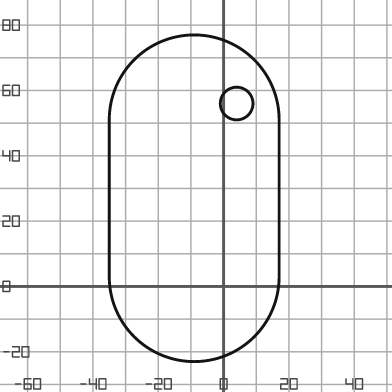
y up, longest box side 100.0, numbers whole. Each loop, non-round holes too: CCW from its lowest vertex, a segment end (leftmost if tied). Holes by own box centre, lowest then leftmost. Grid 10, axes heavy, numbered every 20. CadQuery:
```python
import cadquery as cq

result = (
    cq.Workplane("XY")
    .moveTo(-35.0, 3.0)
    .threePointArc((-9.0, -23.0), (17.0, 3.0))
    .lineTo(17.0, 51.0)
    .threePointArc((-9.0, 77.0), (-35.0, 51.0))
    .close()
    .moveTo(4.0, 56.0)
    .circle(5.0)
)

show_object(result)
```